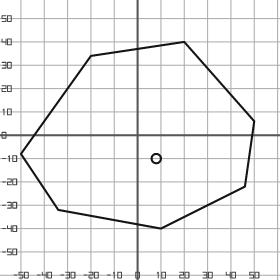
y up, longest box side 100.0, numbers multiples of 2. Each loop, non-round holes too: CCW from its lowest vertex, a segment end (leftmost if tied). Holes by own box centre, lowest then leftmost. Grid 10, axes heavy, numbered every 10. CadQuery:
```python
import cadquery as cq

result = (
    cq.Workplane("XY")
    .moveTo(10.0, -40.0)
    .lineTo(46.0, -22.0)
    .lineTo(50.0, 6.0)
    .lineTo(20.0, 40.0)
    .lineTo(-20.0, 34.0)
    .lineTo(-50.0, -8.0)
    .lineTo(-34.0, -32.0)
    .close()
    .moveTo(8.0, -10.0)
    .circle(2.0)
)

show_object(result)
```